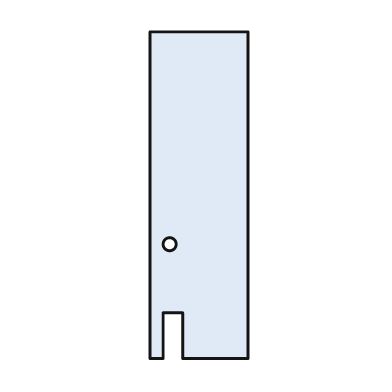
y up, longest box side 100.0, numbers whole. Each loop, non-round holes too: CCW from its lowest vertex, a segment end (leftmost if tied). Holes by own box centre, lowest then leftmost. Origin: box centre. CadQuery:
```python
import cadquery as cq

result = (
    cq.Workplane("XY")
    .moveTo(-15.0, -50.0)
    .lineTo(-11.0, -50.0)
    .lineTo(-11.0, -36.0)
    .lineTo(-5.0, -36.0)
    .lineTo(-5.0, -50.0)
    .lineTo(15.0, -50.0)
    .lineTo(15.0, 50.0)
    .lineTo(-15.0, 50.0)
    .close()
    .moveTo(-9.0, -15.0)
    .circle(2.0)
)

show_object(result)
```